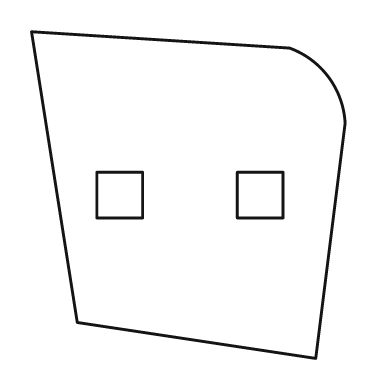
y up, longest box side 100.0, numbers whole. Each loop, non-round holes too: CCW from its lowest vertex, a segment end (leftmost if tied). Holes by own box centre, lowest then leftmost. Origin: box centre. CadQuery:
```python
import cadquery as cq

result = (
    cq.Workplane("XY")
    .moveTo(39.0, -50.0)
    .lineTo(48.0, 22.0)
    .threePointArc((43.0, 36.0), (31.0, 45.0))
    .lineTo(-48.0, 50.0)
    .lineTo(-34.0, -39.0)
    .close()
    .moveTo(-28.0, -7.0)
    .lineTo(-14.0, -7.0)
    .lineTo(-14.0, 7.0)
    .lineTo(-28.0, 7.0)
    .close()
    .moveTo(15.0, -7.0)
    .lineTo(29.0, -7.0)
    .lineTo(29.0, 7.0)
    .lineTo(15.0, 7.0)
    .close()
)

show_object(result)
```